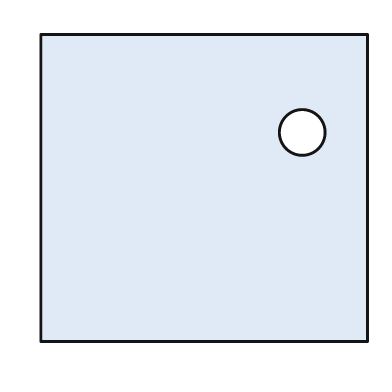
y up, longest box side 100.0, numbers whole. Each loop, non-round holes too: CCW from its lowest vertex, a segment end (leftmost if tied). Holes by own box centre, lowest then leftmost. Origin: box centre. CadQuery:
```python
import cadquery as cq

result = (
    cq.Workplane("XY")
    .moveTo(-50.0, -47.0)
    .lineTo(50.0, -47.0)
    .lineTo(50.0, 47.0)
    .lineTo(-50.0, 47.0)
    .close()
    .moveTo(30.0, 17.0)
    .circle(7.0)
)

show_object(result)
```